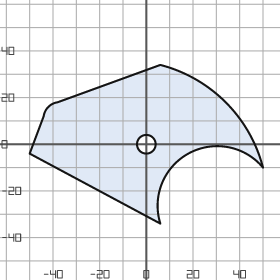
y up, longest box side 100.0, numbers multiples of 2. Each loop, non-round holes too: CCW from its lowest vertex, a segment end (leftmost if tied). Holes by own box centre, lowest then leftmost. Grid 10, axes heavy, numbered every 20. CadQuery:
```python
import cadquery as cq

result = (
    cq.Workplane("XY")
    .moveTo(6.0, -34.0)
    .threePointArc((18.0, -4.0), (50.0, -10.0))
    .threePointArc((34.0, 18.0), (6.0, 34.0))
    .lineTo(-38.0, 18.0)
    .threePointArc((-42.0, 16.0), (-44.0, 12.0))
    .lineTo(-50.0, -4.0)
    .close()
    .moveTo(0.0, 0.0)
    .circle(4.0)
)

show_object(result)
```